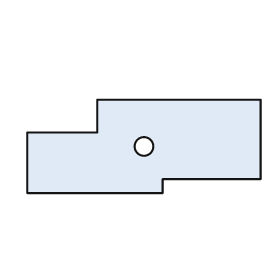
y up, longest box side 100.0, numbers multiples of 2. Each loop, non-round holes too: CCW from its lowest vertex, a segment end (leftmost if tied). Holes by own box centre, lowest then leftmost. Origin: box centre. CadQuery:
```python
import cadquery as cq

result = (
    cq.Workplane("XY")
    .moveTo(-50.0, -20.0)
    .lineTo(8.0, -20.0)
    .lineTo(8.0, -14.0)
    .lineTo(50.0, -14.0)
    .lineTo(50.0, 20.0)
    .lineTo(-20.0, 20.0)
    .lineTo(-20.0, 6.0)
    .lineTo(-50.0, 6.0)
    .close()
    .moveTo(0.0, 0.0)
    .circle(4.0)
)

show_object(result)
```